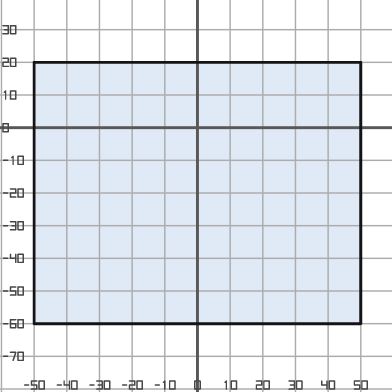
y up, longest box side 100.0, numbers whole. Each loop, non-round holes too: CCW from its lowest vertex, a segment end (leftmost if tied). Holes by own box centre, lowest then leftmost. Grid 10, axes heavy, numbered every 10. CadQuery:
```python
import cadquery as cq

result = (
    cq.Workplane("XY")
    .moveTo(-50.0, -60.0)
    .lineTo(50.0, -60.0)
    .lineTo(50.0, 20.0)
    .lineTo(-50.0, 20.0)
    .close()
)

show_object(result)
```